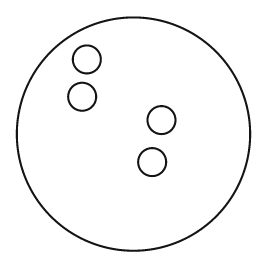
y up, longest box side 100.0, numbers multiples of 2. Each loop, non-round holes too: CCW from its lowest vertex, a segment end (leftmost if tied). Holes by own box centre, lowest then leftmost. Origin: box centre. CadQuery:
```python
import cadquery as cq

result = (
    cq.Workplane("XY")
    .moveTo(0.0, 0.0)
    .circle(50.0)
    .moveTo(8.0, -12.0)
    .circle(6.0)
    .moveTo(12.0, 6.0)
    .circle(6.0)
    .moveTo(-22.0, 16.0)
    .circle(6.0)
    .moveTo(-20.0, 32.0)
    .circle(6.0)
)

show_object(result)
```